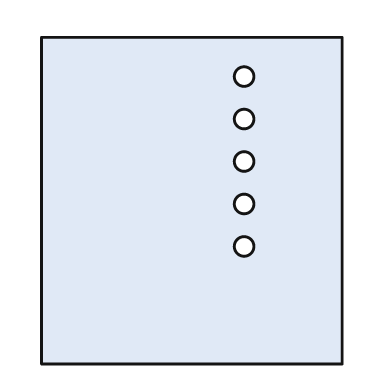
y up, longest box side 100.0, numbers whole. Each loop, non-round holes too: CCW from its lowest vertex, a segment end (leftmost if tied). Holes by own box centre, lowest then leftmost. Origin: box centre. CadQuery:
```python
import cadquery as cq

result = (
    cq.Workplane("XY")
    .moveTo(-46.0, -50.0)
    .lineTo(46.0, -50.0)
    .lineTo(46.0, 50.0)
    .lineTo(-46.0, 50.0)
    .close()
    .moveTo(16.0, -14.0)
    .circle(3.0)
    .moveTo(16.0, -1.0)
    .circle(3.0)
    .moveTo(16.0, 12.0)
    .circle(3.0)
    .moveTo(16.0, 25.0)
    .circle(3.0)
    .moveTo(16.0, 38.0)
    .circle(3.0)
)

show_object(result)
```